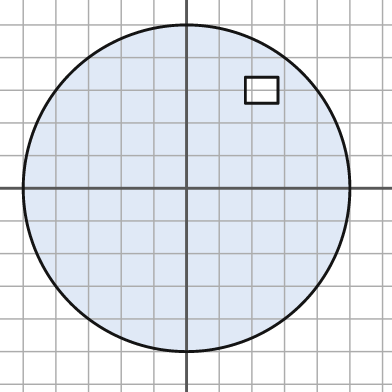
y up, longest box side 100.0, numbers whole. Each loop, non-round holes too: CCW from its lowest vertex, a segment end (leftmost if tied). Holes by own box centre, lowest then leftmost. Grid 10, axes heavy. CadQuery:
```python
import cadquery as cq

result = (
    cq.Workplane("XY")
    .moveTo(0.0, 0.0)
    .circle(50.0)
    .moveTo(18.0, 26.0)
    .lineTo(28.0, 26.0)
    .lineTo(28.0, 34.0)
    .lineTo(18.0, 34.0)
    .close()
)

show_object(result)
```